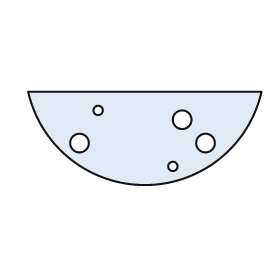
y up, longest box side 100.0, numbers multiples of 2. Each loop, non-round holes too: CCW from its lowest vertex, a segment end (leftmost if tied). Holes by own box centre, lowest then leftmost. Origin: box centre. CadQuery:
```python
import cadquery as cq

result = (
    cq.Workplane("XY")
    .moveTo(-50.0, 20.0)
    .threePointArc((0.0, -20.0), (50.0, 20.0))
    .close()
    .moveTo(12.0, -12.0)
    .circle(2.0)
    .moveTo(-28.0, -2.0)
    .circle(4.0)
    .moveTo(26.0, -2.0)
    .circle(4.0)
    .moveTo(16.0, 8.0)
    .circle(4.0)
    .moveTo(-20.0, 12.0)
    .circle(2.0)
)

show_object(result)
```